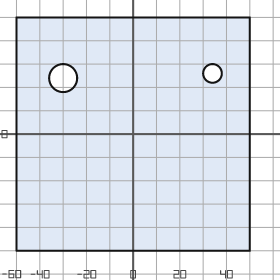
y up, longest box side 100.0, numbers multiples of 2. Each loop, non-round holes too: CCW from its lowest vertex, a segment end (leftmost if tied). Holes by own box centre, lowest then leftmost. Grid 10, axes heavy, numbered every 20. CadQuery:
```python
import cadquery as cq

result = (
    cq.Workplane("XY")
    .moveTo(-50.0, -50.0)
    .lineTo(50.0, -50.0)
    .lineTo(50.0, 50.0)
    .lineTo(-50.0, 50.0)
    .close()
    .moveTo(-30.0, 24.0)
    .circle(6.0)
    .moveTo(34.0, 26.0)
    .circle(4.0)
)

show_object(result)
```